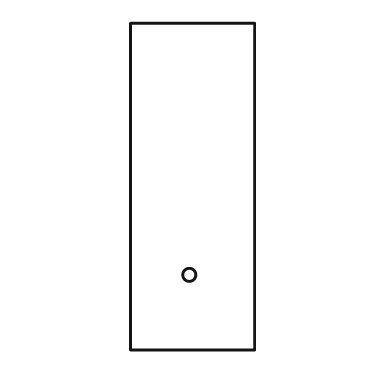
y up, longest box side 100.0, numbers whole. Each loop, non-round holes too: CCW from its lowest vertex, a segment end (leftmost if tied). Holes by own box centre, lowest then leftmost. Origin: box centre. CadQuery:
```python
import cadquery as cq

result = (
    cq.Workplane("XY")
    .moveTo(-19.0, -50.0)
    .lineTo(19.0, -50.0)
    .lineTo(19.0, 50.0)
    .lineTo(-19.0, 50.0)
    .close()
    .moveTo(-1.0, -27.0)
    .circle(2.0)
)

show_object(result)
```